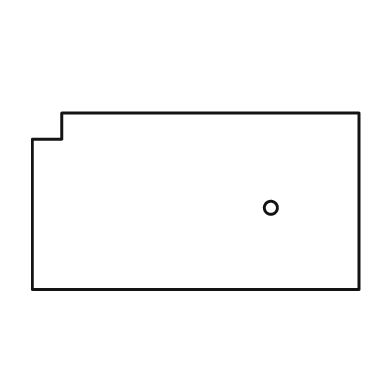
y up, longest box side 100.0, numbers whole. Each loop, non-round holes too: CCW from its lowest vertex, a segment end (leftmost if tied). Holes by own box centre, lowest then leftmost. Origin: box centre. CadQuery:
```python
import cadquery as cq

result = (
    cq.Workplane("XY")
    .moveTo(-50.0, -27.0)
    .lineTo(50.0, -27.0)
    .lineTo(50.0, 27.0)
    .lineTo(-41.0, 27.0)
    .lineTo(-41.0, 19.0)
    .lineTo(-50.0, 19.0)
    .close()
    .moveTo(23.0, -2.0)
    .circle(2.0)
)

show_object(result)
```